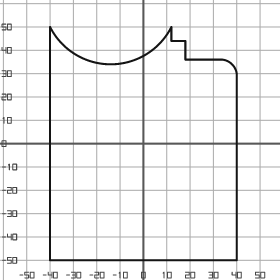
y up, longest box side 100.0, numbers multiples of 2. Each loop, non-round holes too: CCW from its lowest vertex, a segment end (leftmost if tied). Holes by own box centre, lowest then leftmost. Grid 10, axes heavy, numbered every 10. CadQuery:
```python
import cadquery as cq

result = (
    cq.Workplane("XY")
    .moveTo(-40.0, -50.0)
    .lineTo(40.0, -50.0)
    .lineTo(40.0, 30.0)
    .threePointArc((38.0, 34.0), (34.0, 36.0))
    .lineTo(18.0, 36.0)
    .lineTo(18.0, 44.0)
    .lineTo(12.0, 44.0)
    .lineTo(12.0, 50.0)
    .threePointArc((-14.0, 34.0), (-40.0, 50.0))
    .close()
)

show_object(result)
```